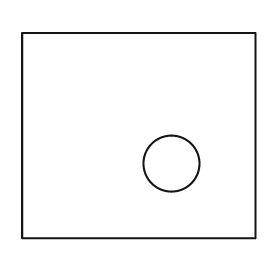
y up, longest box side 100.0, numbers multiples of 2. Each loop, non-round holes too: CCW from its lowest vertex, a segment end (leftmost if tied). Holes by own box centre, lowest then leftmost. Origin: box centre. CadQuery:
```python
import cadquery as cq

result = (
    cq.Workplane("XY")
    .moveTo(-50.0, -44.0)
    .lineTo(50.0, -44.0)
    .lineTo(50.0, 44.0)
    .lineTo(-50.0, 44.0)
    .close()
    .moveTo(14.0, -12.0)
    .circle(12.0)
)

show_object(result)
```